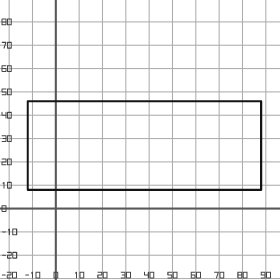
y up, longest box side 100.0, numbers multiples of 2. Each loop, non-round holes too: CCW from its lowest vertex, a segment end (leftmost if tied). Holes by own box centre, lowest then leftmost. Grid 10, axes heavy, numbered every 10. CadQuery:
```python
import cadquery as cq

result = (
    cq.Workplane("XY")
    .moveTo(-12.0, 8.0)
    .lineTo(88.0, 8.0)
    .lineTo(88.0, 46.0)
    .lineTo(-12.0, 46.0)
    .close()
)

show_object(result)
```